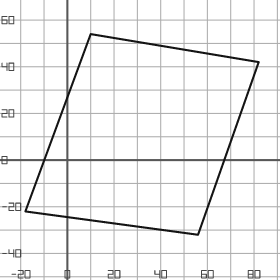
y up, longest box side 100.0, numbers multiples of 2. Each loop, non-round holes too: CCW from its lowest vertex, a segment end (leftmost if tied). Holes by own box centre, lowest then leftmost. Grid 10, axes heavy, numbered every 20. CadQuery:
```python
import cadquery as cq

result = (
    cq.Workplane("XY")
    .moveTo(56.0, -32.0)
    .lineTo(82.0, 42.0)
    .lineTo(10.0, 54.0)
    .lineTo(-18.0, -22.0)
    .close()
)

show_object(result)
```